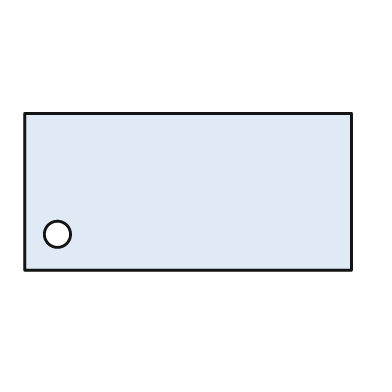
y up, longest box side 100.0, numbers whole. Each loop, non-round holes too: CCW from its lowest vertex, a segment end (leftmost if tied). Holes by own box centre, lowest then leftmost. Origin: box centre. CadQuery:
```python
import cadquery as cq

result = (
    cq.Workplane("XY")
    .moveTo(-50.0, -24.0)
    .lineTo(50.0, -24.0)
    .lineTo(50.0, 24.0)
    .lineTo(-50.0, 24.0)
    .close()
    .moveTo(-40.0, -13.0)
    .circle(4.0)
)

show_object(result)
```